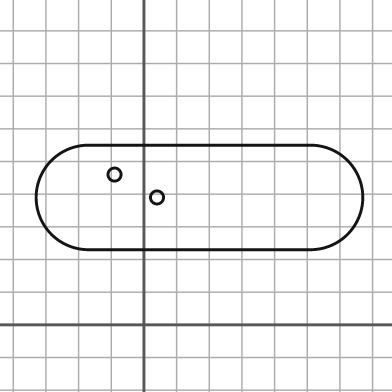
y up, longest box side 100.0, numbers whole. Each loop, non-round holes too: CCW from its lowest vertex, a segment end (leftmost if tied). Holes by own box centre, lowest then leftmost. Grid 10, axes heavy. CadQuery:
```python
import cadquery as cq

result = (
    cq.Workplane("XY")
    .moveTo(-17.0, 23.0)
    .lineTo(51.0, 23.0)
    .threePointArc((67.0, 39.0), (51.0, 55.0))
    .lineTo(-17.0, 55.0)
    .threePointArc((-33.0, 39.0), (-17.0, 23.0))
    .close()
    .moveTo(4.0, 39.0)
    .circle(2.0)
    .moveTo(-9.0, 46.0)
    .circle(2.0)
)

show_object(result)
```